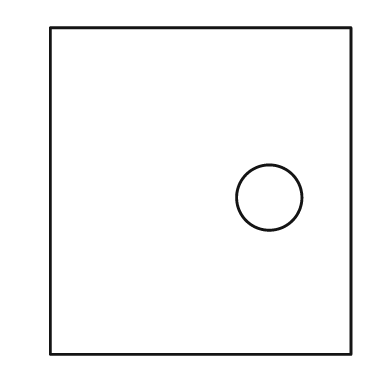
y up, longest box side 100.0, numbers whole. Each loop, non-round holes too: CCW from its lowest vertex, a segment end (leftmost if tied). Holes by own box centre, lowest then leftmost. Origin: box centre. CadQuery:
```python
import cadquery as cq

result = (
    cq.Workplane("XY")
    .moveTo(-46.0, -50.0)
    .lineTo(46.0, -50.0)
    .lineTo(46.0, 50.0)
    .lineTo(-46.0, 50.0)
    .close()
    .moveTo(21.0, -2.0)
    .circle(10.0)
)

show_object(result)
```